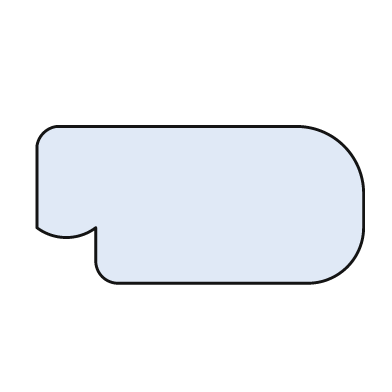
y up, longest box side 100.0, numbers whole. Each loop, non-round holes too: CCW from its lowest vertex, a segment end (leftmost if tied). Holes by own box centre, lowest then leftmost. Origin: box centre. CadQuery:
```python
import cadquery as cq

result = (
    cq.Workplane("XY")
    .moveTo(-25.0, -24.0)
    .lineTo(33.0, -24.0)
    .threePointArc((45.0, -19.0), (50.0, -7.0))
    .lineTo(50.0, 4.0)
    .threePointArc((44.0, 18.0), (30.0, 24.0))
    .lineTo(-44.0, 24.0)
    .threePointArc((-48.0, 22.0), (-50.0, 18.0))
    .lineTo(-50.0, -7.0)
    .threePointArc((-41.0, -10.0), (-32.0, -7.0))
    .lineTo(-32.0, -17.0)
    .threePointArc((-30.0, -22.0), (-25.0, -24.0))
    .close()
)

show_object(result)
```